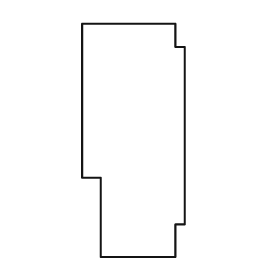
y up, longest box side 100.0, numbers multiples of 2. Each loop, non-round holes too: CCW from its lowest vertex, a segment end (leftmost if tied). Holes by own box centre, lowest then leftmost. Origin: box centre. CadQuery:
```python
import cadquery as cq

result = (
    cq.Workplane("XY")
    .moveTo(-14.0, -50.0)
    .lineTo(18.0, -50.0)
    .lineTo(18.0, -36.0)
    .lineTo(22.0, -36.0)
    .lineTo(22.0, 40.0)
    .lineTo(18.0, 40.0)
    .lineTo(18.0, 50.0)
    .lineTo(-22.0, 50.0)
    .lineTo(-22.0, -16.0)
    .lineTo(-14.0, -16.0)
    .close()
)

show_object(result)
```